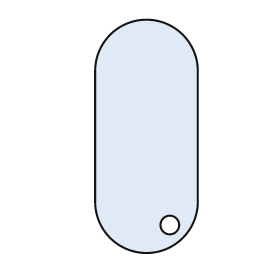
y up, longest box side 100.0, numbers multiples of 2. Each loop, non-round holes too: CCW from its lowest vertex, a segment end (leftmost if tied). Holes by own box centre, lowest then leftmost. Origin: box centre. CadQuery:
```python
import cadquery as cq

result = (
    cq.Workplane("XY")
    .moveTo(-22.0, -28.0)
    .threePointArc((0.0, -50.0), (22.0, -28.0))
    .lineTo(22.0, 28.0)
    .threePointArc((0.0, 50.0), (-22.0, 28.0))
    .close()
    .moveTo(10.0, -38.0)
    .circle(4.0)
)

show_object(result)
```